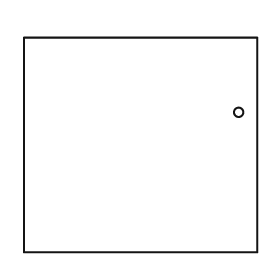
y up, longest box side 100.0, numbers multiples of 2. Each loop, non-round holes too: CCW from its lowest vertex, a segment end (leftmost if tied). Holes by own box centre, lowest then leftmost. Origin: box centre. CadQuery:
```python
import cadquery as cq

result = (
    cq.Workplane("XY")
    .moveTo(-50.0, -46.0)
    .lineTo(50.0, -46.0)
    .lineTo(50.0, 46.0)
    .lineTo(-50.0, 46.0)
    .close()
    .moveTo(42.0, 14.0)
    .circle(2.0)
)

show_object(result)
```